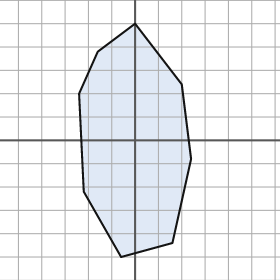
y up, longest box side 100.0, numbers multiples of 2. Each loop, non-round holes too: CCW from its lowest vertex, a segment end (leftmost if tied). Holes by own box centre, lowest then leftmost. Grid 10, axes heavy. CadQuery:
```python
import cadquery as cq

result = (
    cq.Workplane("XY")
    .moveTo(-6.0, -50.0)
    .lineTo(16.0, -44.0)
    .lineTo(24.0, -8.0)
    .lineTo(20.0, 24.0)
    .lineTo(0.0, 50.0)
    .lineTo(-16.0, 38.0)
    .lineTo(-24.0, 20.0)
    .lineTo(-22.0, -22.0)
    .close()
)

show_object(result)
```